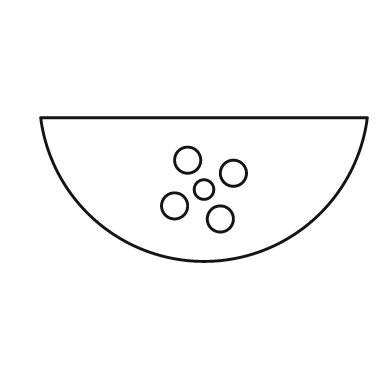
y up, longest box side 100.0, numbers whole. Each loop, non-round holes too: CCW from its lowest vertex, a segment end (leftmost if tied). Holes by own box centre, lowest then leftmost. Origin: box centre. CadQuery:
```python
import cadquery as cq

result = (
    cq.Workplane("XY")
    .moveTo(-50.0, 22.0)
    .threePointArc((0.0, -22.0), (50.0, 22.0))
    .close()
    .moveTo(5.0, -9.0)
    .circle(4.0)
    .moveTo(-9.0, -5.0)
    .circle(4.0)
    .moveTo(0.0, 0.0)
    .circle(3.0)
    .moveTo(9.0, 5.0)
    .circle(4.0)
    .moveTo(-5.0, 9.0)
    .circle(4.0)
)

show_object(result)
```